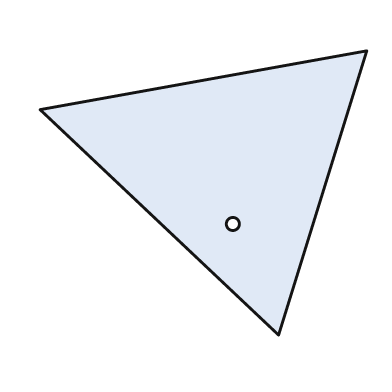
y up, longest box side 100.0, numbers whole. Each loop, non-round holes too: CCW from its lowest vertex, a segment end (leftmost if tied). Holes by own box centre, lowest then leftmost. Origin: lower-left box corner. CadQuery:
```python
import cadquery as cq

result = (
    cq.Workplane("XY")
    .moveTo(73.0, 0.0)
    .lineTo(100.0, 87.0)
    .lineTo(0.0, 69.0)
    .close()
    .moveTo(59.0, 34.0)
    .circle(2.0)
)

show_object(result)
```